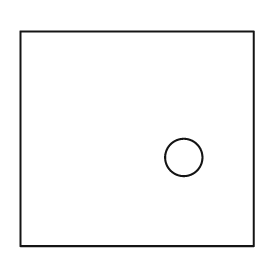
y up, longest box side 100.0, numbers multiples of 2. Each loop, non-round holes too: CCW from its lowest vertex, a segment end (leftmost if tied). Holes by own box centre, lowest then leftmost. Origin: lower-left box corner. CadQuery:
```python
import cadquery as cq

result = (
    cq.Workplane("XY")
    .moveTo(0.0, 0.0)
    .lineTo(100.0, 0.0)
    .lineTo(100.0, 92.0)
    .lineTo(0.0, 92.0)
    .close()
    .moveTo(70.0, 38.0)
    .circle(8.0)
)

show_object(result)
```